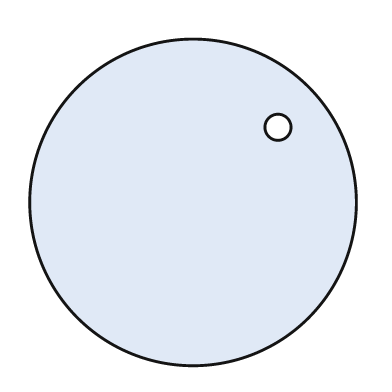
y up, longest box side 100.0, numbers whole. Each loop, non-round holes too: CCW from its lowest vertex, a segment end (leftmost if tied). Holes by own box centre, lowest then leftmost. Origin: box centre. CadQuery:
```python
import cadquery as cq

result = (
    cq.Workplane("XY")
    .moveTo(0.0, 0.0)
    .circle(50.0)
    .moveTo(26.0, 23.0)
    .circle(4.0)
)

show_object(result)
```